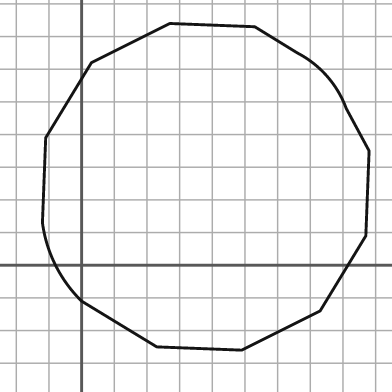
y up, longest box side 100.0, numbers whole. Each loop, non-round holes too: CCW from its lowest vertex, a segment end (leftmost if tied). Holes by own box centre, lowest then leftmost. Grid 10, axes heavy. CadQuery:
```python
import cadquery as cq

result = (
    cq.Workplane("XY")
    .moveTo(49.0, -26.0)
    .lineTo(73.0, -14.0)
    .lineTo(87.0, 9.0)
    .lineTo(88.0, 35.0)
    .lineTo(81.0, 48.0)
    .threePointArc((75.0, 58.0), (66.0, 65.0))
    .lineTo(53.0, 73.0)
    .lineTo(27.0, 74.0)
    .lineTo(3.0, 62.0)
    .lineTo(-11.0, 39.0)
    .lineTo(-12.0, 13.0)
    .threePointArc((-8.0, 0.0), (0.0, -11.0))
    .lineTo(23.0, -25.0)
    .close()
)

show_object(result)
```